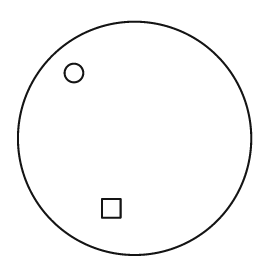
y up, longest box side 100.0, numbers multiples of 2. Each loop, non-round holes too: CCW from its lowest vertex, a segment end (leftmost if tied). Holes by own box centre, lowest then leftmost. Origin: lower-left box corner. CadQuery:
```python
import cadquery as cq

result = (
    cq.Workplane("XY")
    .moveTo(50.0, 50.0)
    .circle(50.0)
    .moveTo(36.0, 16.0)
    .lineTo(44.0, 16.0)
    .lineTo(44.0, 24.0)
    .lineTo(36.0, 24.0)
    .close()
    .moveTo(24.0, 78.0)
    .circle(4.0)
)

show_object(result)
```